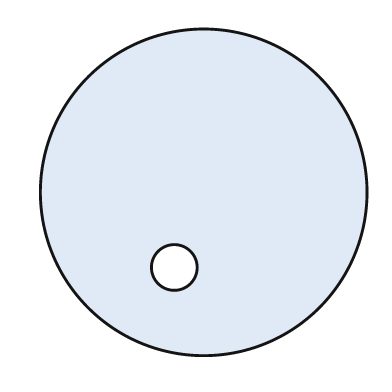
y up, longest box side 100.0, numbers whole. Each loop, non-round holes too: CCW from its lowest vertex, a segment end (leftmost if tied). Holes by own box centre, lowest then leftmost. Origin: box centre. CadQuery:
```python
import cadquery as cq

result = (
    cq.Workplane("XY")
    .moveTo(0.0, 0.0)
    .circle(50.0)
    .moveTo(-9.0, -23.0)
    .circle(7.0)
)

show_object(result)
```